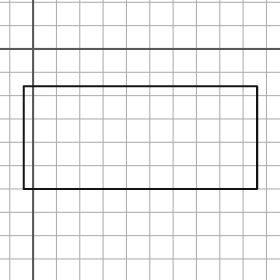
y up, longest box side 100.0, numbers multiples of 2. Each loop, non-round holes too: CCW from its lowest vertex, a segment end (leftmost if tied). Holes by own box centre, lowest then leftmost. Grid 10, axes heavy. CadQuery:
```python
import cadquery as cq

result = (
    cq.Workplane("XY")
    .moveTo(-4.0, -60.0)
    .lineTo(96.0, -60.0)
    .lineTo(96.0, -16.0)
    .lineTo(-4.0, -16.0)
    .close()
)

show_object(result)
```